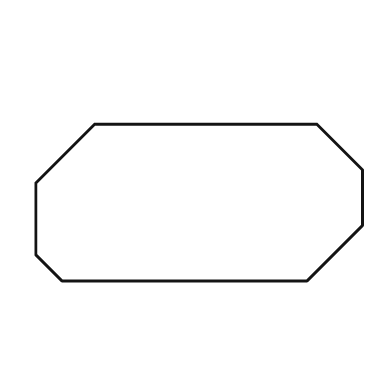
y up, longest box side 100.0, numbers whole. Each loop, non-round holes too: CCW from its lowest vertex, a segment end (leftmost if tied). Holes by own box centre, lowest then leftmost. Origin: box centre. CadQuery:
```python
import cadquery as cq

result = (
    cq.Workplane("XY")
    .moveTo(-42.0, -24.0)
    .lineTo(33.0, -24.0)
    .lineTo(50.0, -7.0)
    .lineTo(50.0, 10.0)
    .lineTo(36.0, 24.0)
    .lineTo(-32.0, 24.0)
    .lineTo(-50.0, 6.0)
    .lineTo(-50.0, -16.0)
    .close()
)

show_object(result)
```